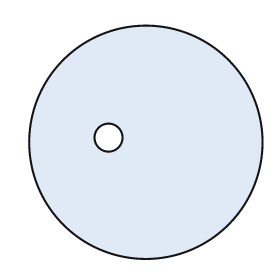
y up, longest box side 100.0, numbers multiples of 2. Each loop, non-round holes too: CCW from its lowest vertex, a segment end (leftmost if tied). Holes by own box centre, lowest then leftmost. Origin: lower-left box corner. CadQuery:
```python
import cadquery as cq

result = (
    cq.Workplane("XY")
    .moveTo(50.0, 50.0)
    .circle(50.0)
    .moveTo(34.0, 52.0)
    .circle(6.0)
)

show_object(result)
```